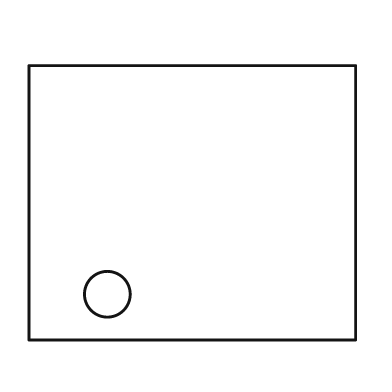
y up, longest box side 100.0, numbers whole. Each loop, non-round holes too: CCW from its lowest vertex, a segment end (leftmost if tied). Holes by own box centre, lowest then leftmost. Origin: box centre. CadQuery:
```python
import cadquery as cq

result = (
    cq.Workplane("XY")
    .moveTo(-50.0, -42.0)
    .lineTo(50.0, -42.0)
    .lineTo(50.0, 42.0)
    .lineTo(-50.0, 42.0)
    .close()
    .moveTo(-26.0, -28.0)
    .circle(7.0)
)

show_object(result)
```